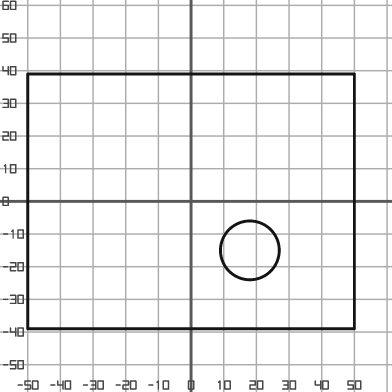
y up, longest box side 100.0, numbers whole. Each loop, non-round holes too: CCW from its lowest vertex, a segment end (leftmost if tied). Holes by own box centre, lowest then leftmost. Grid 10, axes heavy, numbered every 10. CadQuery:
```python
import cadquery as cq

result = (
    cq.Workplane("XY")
    .moveTo(-50.0, -39.0)
    .lineTo(50.0, -39.0)
    .lineTo(50.0, 39.0)
    .lineTo(-50.0, 39.0)
    .close()
    .moveTo(18.0, -15.0)
    .circle(9.0)
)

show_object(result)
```